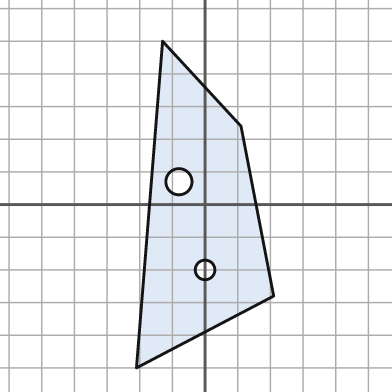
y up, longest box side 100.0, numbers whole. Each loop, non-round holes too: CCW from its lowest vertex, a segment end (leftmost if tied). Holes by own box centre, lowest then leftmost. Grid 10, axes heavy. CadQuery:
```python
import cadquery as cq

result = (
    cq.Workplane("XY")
    .moveTo(-21.0, -50.0)
    .lineTo(21.0, -28.0)
    .lineTo(11.0, 24.0)
    .lineTo(-13.0, 50.0)
    .close()
    .moveTo(0.0, -20.0)
    .circle(3.0)
    .moveTo(-8.0, 7.0)
    .circle(4.0)
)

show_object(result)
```